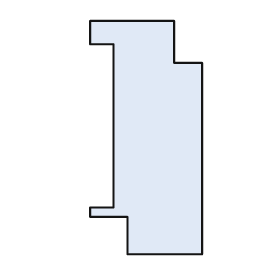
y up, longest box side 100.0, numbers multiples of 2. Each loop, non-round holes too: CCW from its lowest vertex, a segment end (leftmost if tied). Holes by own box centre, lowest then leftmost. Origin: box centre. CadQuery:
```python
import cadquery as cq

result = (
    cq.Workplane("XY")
    .moveTo(-8.0, -50.0)
    .lineTo(24.0, -50.0)
    .lineTo(24.0, 32.0)
    .lineTo(12.0, 32.0)
    .lineTo(12.0, 50.0)
    .lineTo(-24.0, 50.0)
    .lineTo(-24.0, 40.0)
    .lineTo(-14.0, 40.0)
    .lineTo(-14.0, -30.0)
    .lineTo(-24.0, -30.0)
    .lineTo(-24.0, -34.0)
    .lineTo(-8.0, -34.0)
    .close()
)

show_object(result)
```